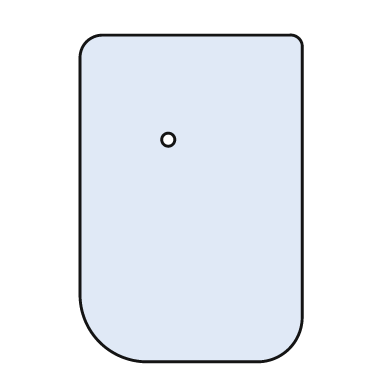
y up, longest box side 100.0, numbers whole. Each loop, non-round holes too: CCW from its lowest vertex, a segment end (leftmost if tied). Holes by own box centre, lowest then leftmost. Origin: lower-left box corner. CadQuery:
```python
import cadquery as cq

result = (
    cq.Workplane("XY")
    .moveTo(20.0, 0.0)
    .lineTo(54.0, 0.0)
    .threePointArc((64.0, 4.0), (68.0, 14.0))
    .lineTo(68.0, 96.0)
    .threePointArc((67.0, 99.0), (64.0, 100.0))
    .lineTo(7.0, 100.0)
    .threePointArc((2.0, 98.0), (0.0, 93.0))
    .lineTo(0.0, 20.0)
    .threePointArc((6.0, 6.0), (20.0, 0.0))
    .close()
    .moveTo(27.0, 68.0)
    .circle(2.0)
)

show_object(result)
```